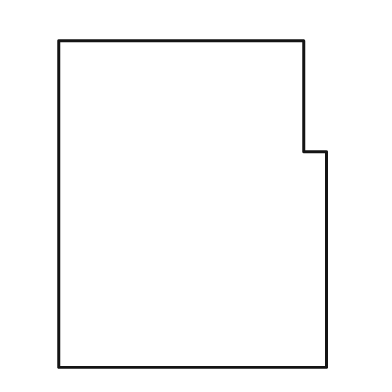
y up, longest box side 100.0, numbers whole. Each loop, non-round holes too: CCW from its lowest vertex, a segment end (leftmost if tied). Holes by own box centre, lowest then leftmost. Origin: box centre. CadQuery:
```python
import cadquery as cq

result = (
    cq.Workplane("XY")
    .moveTo(-41.0, -50.0)
    .lineTo(41.0, -50.0)
    .lineTo(41.0, 16.0)
    .lineTo(34.0, 16.0)
    .lineTo(34.0, 50.0)
    .lineTo(-41.0, 50.0)
    .close()
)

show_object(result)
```